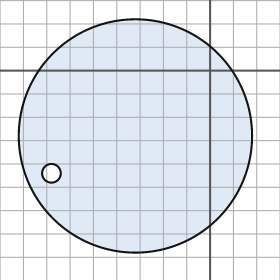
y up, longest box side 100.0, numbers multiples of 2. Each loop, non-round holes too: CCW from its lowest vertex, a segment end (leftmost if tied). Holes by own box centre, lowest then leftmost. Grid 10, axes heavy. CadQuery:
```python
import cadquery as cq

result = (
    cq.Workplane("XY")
    .moveTo(-32.0, -28.0)
    .circle(50.0)
    .moveTo(-68.0, -44.0)
    .circle(4.0)
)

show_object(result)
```